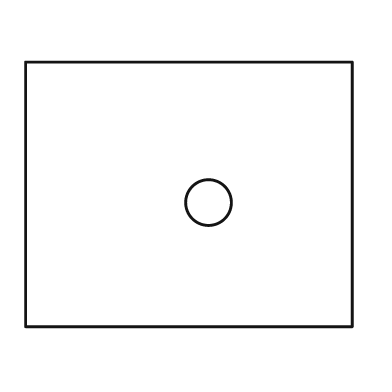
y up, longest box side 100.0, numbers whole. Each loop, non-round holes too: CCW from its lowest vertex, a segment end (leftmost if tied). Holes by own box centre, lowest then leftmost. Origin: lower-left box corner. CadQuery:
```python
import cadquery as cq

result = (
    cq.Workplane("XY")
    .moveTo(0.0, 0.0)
    .lineTo(100.0, 0.0)
    .lineTo(100.0, 81.0)
    .lineTo(0.0, 81.0)
    .close()
    .moveTo(56.0, 38.0)
    .circle(7.0)
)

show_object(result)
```